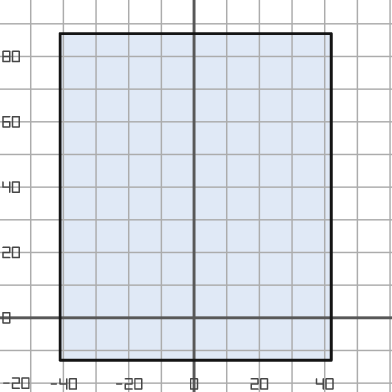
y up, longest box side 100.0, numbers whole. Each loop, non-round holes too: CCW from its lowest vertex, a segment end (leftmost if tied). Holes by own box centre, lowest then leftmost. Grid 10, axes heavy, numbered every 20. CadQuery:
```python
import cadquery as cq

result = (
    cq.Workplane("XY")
    .moveTo(-41.0, -13.0)
    .lineTo(42.0, -13.0)
    .lineTo(42.0, 87.0)
    .lineTo(-41.0, 87.0)
    .close()
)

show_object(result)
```